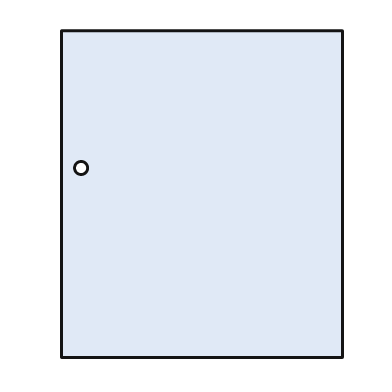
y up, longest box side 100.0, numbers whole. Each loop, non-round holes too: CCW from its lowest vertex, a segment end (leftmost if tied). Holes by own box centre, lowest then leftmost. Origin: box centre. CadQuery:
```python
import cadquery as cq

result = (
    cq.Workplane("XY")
    .moveTo(-43.0, -50.0)
    .lineTo(43.0, -50.0)
    .lineTo(43.0, 50.0)
    .lineTo(-43.0, 50.0)
    .close()
    .moveTo(-37.0, 8.0)
    .circle(2.0)
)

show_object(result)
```